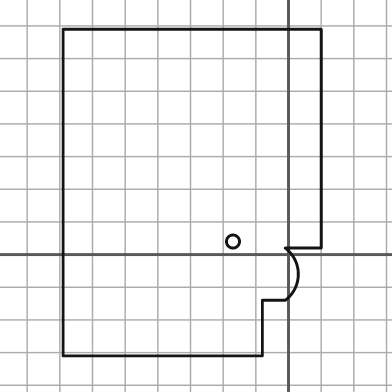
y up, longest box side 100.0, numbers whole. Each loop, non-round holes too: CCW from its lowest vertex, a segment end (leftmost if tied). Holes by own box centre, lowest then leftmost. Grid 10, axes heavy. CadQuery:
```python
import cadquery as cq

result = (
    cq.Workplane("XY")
    .moveTo(-69.0, -31.0)
    .lineTo(-8.0, -31.0)
    .lineTo(-8.0, -14.0)
    .lineTo(-1.0, -14.0)
    .threePointArc((3.0, -6.0), (-1.0, 2.0))
    .lineTo(10.0, 2.0)
    .lineTo(10.0, 69.0)
    .lineTo(-69.0, 69.0)
    .close()
    .moveTo(-17.0, 4.0)
    .circle(2.0)
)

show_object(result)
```